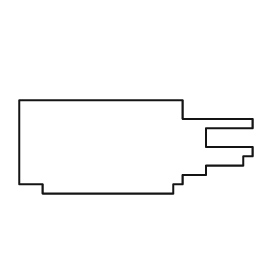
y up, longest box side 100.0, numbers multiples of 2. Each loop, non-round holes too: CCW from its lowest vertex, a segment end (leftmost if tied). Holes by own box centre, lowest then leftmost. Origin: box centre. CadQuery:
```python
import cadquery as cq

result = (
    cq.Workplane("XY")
    .moveTo(-40.0, -20.0)
    .lineTo(16.0, -20.0)
    .lineTo(16.0, -16.0)
    .lineTo(20.0, -16.0)
    .lineTo(20.0, -12.0)
    .lineTo(30.0, -12.0)
    .lineTo(30.0, -8.0)
    .lineTo(46.0, -8.0)
    .lineTo(46.0, -4.0)
    .lineTo(50.0, -4.0)
    .lineTo(50.0, 0.0)
    .lineTo(30.0, 0.0)
    .lineTo(30.0, 8.0)
    .lineTo(50.0, 8.0)
    .lineTo(50.0, 12.0)
    .lineTo(20.0, 12.0)
    .lineTo(20.0, 20.0)
    .lineTo(-50.0, 20.0)
    .lineTo(-50.0, -16.0)
    .lineTo(-40.0, -16.0)
    .close()
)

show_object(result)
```